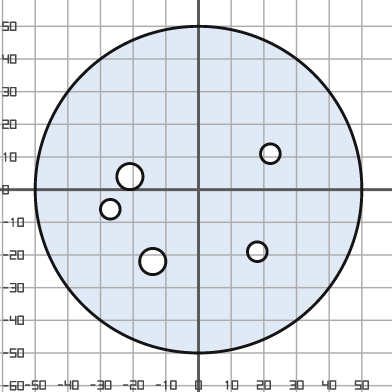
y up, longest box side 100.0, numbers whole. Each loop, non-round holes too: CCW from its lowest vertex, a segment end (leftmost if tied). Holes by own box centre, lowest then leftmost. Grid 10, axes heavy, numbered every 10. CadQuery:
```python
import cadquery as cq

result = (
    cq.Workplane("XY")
    .moveTo(0.0, 0.0)
    .circle(50.0)
    .moveTo(-14.0, -22.0)
    .circle(4.0)
    .moveTo(18.0, -19.0)
    .circle(3.0)
    .moveTo(-27.0, -6.0)
    .circle(3.0)
    .moveTo(-21.0, 4.0)
    .circle(4.0)
    .moveTo(22.0, 11.0)
    .circle(3.0)
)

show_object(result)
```